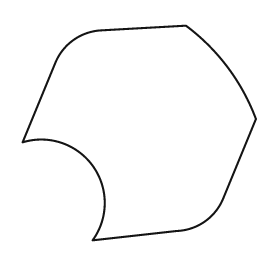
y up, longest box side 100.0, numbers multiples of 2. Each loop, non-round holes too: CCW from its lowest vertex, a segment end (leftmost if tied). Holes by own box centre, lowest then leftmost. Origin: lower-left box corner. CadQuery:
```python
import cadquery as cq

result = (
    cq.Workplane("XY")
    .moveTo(30.0, 0.0)
    .lineTo(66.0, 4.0)
    .threePointArc((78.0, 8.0), (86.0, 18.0))
    .lineTo(100.0, 52.0)
    .threePointArc((88.0, 74.0), (70.0, 92.0))
    .lineTo(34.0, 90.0)
    .threePointArc((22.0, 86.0), (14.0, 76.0))
    .lineTo(0.0, 42.0)
    .threePointArc((30.0, 32.0), (30.0, 0.0))
    .close()
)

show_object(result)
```